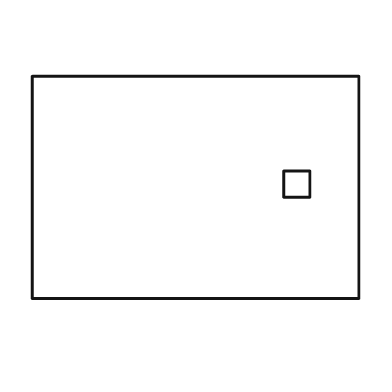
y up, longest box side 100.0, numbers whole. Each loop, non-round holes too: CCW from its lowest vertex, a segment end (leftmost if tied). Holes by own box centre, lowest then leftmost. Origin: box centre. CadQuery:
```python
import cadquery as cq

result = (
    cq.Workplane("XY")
    .moveTo(-50.0, -34.0)
    .lineTo(50.0, -34.0)
    .lineTo(50.0, 34.0)
    .lineTo(-50.0, 34.0)
    .close()
    .moveTo(27.0, -3.0)
    .lineTo(35.0, -3.0)
    .lineTo(35.0, 5.0)
    .lineTo(27.0, 5.0)
    .close()
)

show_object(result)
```